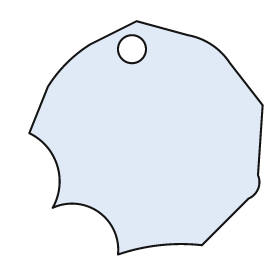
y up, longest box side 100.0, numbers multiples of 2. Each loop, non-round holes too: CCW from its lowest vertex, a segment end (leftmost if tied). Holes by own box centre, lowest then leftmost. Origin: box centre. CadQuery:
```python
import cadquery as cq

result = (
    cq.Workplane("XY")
    .moveTo(-12.0, -50.0)
    .threePointArc((6.0, -46.0), (24.0, -46.0))
    .lineTo(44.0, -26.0)
    .threePointArc((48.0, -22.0), (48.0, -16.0))
    .lineTo(50.0, 14.0)
    .lineTo(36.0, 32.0)
    .threePointArc((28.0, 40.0), (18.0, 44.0))
    .lineTo(-4.0, 50.0)
    .lineTo(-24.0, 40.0)
    .threePointArc((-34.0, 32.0), (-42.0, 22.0))
    .lineTo(-50.0, 2.0)
    .threePointArc((-38.0, -12.0), (-40.0, -30.0))
    .threePointArc((-20.0, -32.0), (-12.0, -50.0))
    .close()
    .moveTo(-6.0, 38.0)
    .circle(6.0)
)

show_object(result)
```